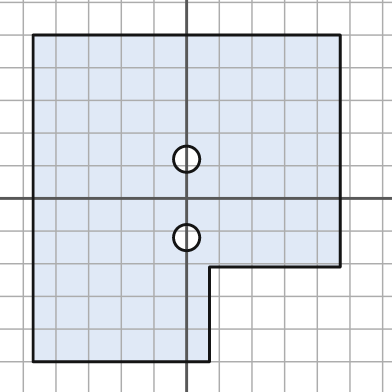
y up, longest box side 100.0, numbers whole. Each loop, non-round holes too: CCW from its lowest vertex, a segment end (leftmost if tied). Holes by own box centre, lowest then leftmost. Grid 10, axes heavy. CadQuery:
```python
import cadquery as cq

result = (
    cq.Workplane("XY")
    .moveTo(-47.0, -50.0)
    .lineTo(7.0, -50.0)
    .lineTo(7.0, -21.0)
    .lineTo(47.0, -21.0)
    .lineTo(47.0, 50.0)
    .lineTo(-47.0, 50.0)
    .close()
    .moveTo(0.0, -12.0)
    .circle(4.0)
    .moveTo(0.0, 12.0)
    .circle(4.0)
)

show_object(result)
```